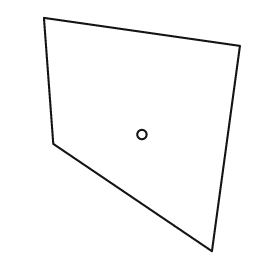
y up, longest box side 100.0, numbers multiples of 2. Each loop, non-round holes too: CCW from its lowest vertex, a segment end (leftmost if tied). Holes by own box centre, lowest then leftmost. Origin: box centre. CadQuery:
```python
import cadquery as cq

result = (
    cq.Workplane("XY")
    .moveTo(30.0, -50.0)
    .lineTo(42.0, 38.0)
    .lineTo(-42.0, 50.0)
    .lineTo(-38.0, -4.0)
    .close()
    .moveTo(0.0, 0.0)
    .circle(2.0)
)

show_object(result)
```